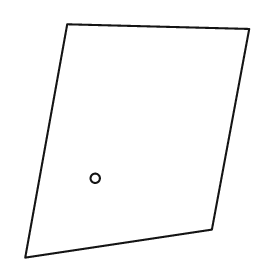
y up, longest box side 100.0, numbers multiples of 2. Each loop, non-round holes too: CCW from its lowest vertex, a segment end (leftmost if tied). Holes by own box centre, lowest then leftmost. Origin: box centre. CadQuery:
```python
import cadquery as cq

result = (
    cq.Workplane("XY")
    .moveTo(-48.0, -50.0)
    .lineTo(32.0, -38.0)
    .lineTo(48.0, 48.0)
    .lineTo(-30.0, 50.0)
    .close()
    .moveTo(-18.0, -16.0)
    .circle(2.0)
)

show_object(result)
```